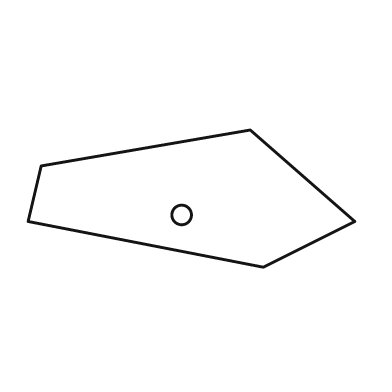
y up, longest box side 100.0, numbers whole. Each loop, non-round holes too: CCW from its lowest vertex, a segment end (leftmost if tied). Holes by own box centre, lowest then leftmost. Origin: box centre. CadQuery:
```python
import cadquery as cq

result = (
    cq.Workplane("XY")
    .moveTo(22.0, -21.0)
    .lineTo(50.0, -7.0)
    .lineTo(18.0, 21.0)
    .lineTo(-46.0, 10.0)
    .lineTo(-50.0, -7.0)
    .close()
    .moveTo(-3.0, -5.0)
    .circle(3.0)
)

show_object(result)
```